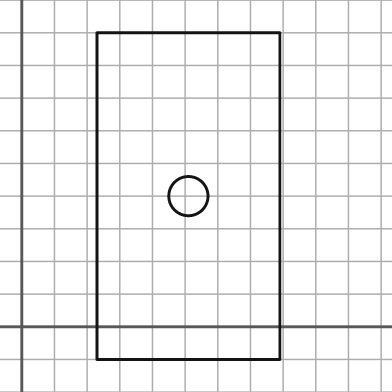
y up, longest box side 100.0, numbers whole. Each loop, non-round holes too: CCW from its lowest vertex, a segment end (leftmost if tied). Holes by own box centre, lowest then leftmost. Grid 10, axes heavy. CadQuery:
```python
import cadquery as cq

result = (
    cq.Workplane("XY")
    .moveTo(23.0, -10.0)
    .lineTo(79.0, -10.0)
    .lineTo(79.0, 90.0)
    .lineTo(23.0, 90.0)
    .close()
    .moveTo(51.0, 40.0)
    .circle(6.0)
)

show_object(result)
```